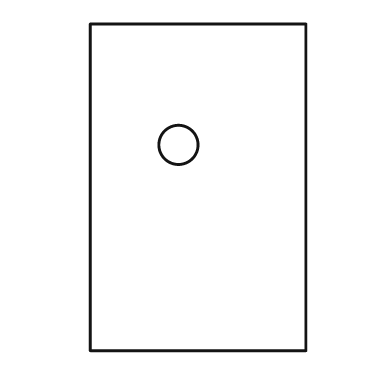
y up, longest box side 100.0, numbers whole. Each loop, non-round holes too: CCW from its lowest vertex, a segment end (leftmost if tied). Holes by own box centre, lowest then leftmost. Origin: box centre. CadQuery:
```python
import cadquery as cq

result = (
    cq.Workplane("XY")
    .moveTo(-33.0, -50.0)
    .lineTo(33.0, -50.0)
    .lineTo(33.0, 50.0)
    .lineTo(-33.0, 50.0)
    .close()
    .moveTo(-6.0, 13.0)
    .circle(6.0)
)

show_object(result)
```